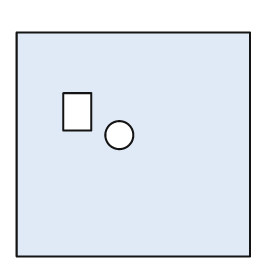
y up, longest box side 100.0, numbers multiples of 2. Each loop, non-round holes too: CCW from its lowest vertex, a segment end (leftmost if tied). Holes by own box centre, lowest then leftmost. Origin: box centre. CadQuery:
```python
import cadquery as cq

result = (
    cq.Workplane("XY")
    .moveTo(-50.0, -48.0)
    .lineTo(50.0, -48.0)
    .lineTo(50.0, 48.0)
    .lineTo(-50.0, 48.0)
    .close()
    .moveTo(-6.0, 4.0)
    .circle(6.0)
    .moveTo(-30.0, 6.0)
    .lineTo(-18.0, 6.0)
    .lineTo(-18.0, 22.0)
    .lineTo(-30.0, 22.0)
    .close()
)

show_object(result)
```